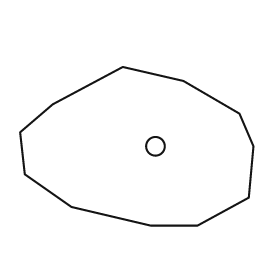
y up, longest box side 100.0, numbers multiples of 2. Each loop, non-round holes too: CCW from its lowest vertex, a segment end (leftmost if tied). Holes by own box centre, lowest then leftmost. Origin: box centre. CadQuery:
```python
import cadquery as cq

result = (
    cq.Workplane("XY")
    .moveTo(6.0, -34.0)
    .lineTo(26.0, -34.0)
    .lineTo(48.0, -22.0)
    .lineTo(50.0, 0.0)
    .lineTo(44.0, 14.0)
    .lineTo(20.0, 28.0)
    .lineTo(-6.0, 34.0)
    .lineTo(-36.0, 18.0)
    .lineTo(-50.0, 6.0)
    .lineTo(-48.0, -12.0)
    .lineTo(-28.0, -26.0)
    .close()
    .moveTo(8.0, 0.0)
    .circle(4.0)
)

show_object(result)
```